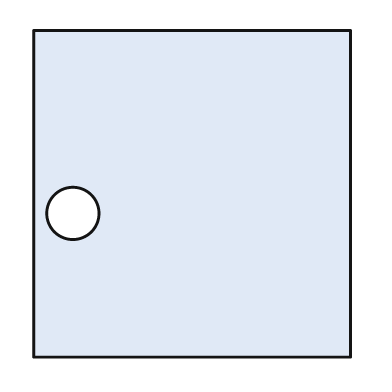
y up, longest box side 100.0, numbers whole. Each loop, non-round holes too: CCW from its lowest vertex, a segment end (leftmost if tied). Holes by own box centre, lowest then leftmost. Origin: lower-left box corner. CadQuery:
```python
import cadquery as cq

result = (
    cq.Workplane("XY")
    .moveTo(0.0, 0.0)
    .lineTo(97.0, 0.0)
    .lineTo(97.0, 100.0)
    .lineTo(0.0, 100.0)
    .close()
    .moveTo(12.0, 44.0)
    .circle(8.0)
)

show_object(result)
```